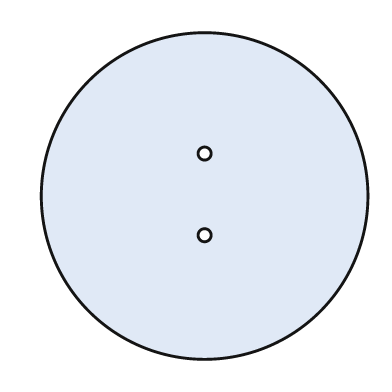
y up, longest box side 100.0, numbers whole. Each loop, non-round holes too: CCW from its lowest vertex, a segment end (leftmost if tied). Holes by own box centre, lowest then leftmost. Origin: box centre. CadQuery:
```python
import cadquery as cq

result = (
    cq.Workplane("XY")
    .moveTo(0.0, 0.0)
    .circle(50.0)
    .moveTo(0.0, -12.0)
    .circle(2.0)
    .moveTo(0.0, 13.0)
    .circle(2.0)
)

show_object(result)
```